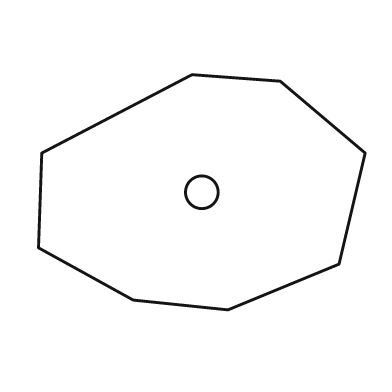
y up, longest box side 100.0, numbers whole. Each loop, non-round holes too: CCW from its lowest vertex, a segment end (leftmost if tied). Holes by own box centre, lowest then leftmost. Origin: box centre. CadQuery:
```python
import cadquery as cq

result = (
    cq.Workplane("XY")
    .moveTo(8.0, -36.0)
    .lineTo(42.0, -22.0)
    .lineTo(50.0, 12.0)
    .lineTo(24.0, 34.0)
    .lineTo(-3.0, 36.0)
    .lineTo(-49.0, 12.0)
    .lineTo(-50.0, -17.0)
    .lineTo(-21.0, -33.0)
    .close()
    .moveTo(0.0, 0.0)
    .circle(5.0)
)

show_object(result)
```